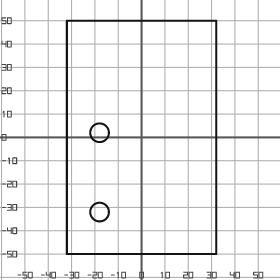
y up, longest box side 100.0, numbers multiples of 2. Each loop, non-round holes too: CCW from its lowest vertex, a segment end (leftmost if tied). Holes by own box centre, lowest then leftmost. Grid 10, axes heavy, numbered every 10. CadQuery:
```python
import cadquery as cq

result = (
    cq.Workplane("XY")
    .moveTo(-32.0, -50.0)
    .lineTo(32.0, -50.0)
    .lineTo(32.0, 50.0)
    .lineTo(-32.0, 50.0)
    .close()
    .moveTo(-18.0, -32.0)
    .circle(4.0)
    .moveTo(-18.0, 2.0)
    .circle(4.0)
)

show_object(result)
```